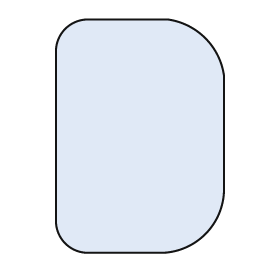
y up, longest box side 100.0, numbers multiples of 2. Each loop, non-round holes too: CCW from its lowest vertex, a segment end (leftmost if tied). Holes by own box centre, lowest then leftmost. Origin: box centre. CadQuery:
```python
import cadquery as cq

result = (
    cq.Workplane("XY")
    .moveTo(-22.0, -50.0)
    .lineTo(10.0, -50.0)
    .threePointArc((28.0, -42.0), (36.0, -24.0))
    .lineTo(36.0, 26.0)
    .threePointArc((28.0, 42.0), (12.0, 50.0))
    .lineTo(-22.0, 50.0)
    .threePointArc((-32.0, 46.0), (-36.0, 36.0))
    .lineTo(-36.0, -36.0)
    .threePointArc((-32.0, -46.0), (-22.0, -50.0))
    .close()
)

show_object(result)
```